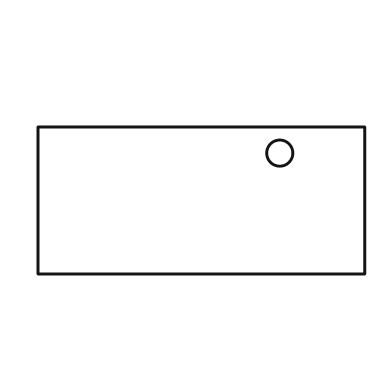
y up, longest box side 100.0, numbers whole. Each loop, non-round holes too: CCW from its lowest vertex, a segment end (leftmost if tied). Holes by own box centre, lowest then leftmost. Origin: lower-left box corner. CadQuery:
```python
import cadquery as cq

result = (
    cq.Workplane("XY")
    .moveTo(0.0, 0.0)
    .lineTo(100.0, 0.0)
    .lineTo(100.0, 45.0)
    .lineTo(0.0, 45.0)
    .close()
    .moveTo(74.0, 37.0)
    .circle(4.0)
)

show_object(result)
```